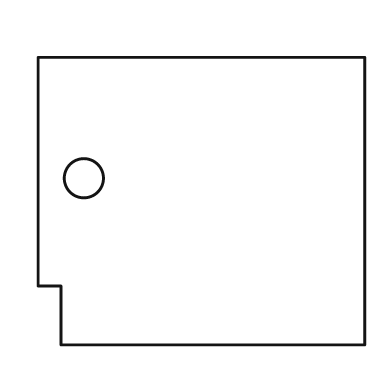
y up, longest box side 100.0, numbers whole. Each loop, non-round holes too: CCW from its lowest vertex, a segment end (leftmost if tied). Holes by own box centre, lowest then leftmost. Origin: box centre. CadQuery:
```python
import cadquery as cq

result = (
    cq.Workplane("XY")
    .moveTo(-43.0, -44.0)
    .lineTo(50.0, -44.0)
    .lineTo(50.0, 44.0)
    .lineTo(-50.0, 44.0)
    .lineTo(-50.0, -26.0)
    .lineTo(-43.0, -26.0)
    .close()
    .moveTo(-36.0, 7.0)
    .circle(6.0)
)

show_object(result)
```